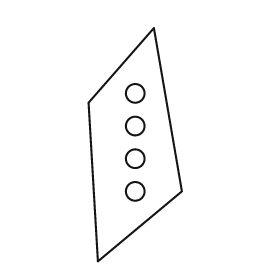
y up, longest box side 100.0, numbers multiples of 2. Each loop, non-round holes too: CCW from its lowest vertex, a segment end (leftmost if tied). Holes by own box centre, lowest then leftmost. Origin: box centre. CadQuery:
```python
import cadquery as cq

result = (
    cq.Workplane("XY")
    .moveTo(-16.0, -50.0)
    .lineTo(20.0, -20.0)
    .lineTo(8.0, 50.0)
    .lineTo(-20.0, 18.0)
    .close()
    .moveTo(0.0, -20.0)
    .circle(4.0)
    .moveTo(0.0, -6.0)
    .circle(4.0)
    .moveTo(0.0, 8.0)
    .circle(4.0)
    .moveTo(0.0, 22.0)
    .circle(4.0)
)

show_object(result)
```